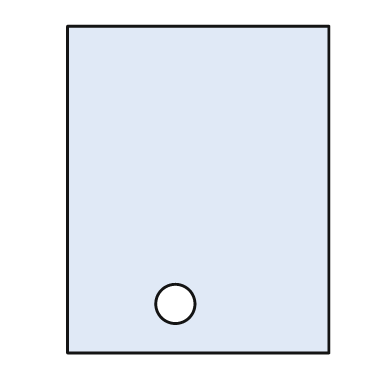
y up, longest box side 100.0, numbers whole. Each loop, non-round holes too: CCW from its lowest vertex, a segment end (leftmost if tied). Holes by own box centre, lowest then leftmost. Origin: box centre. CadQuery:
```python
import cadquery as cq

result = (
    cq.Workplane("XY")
    .moveTo(-40.0, -50.0)
    .lineTo(40.0, -50.0)
    .lineTo(40.0, 50.0)
    .lineTo(-40.0, 50.0)
    .close()
    .moveTo(-7.0, -35.0)
    .circle(6.0)
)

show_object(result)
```